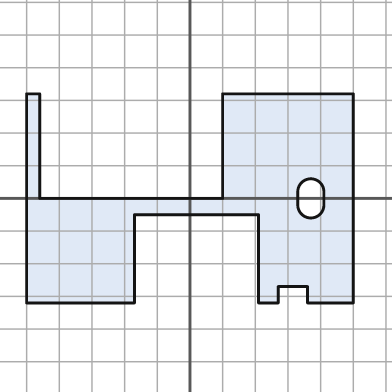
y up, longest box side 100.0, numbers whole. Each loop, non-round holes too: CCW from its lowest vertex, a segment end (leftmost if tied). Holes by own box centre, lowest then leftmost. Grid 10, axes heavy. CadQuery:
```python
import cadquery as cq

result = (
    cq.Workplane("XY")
    .moveTo(-50.0, -32.0)
    .lineTo(-17.0, -32.0)
    .lineTo(-17.0, -5.0)
    .lineTo(21.0, -5.0)
    .lineTo(21.0, -32.0)
    .lineTo(27.0, -32.0)
    .lineTo(27.0, -27.0)
    .lineTo(36.0, -27.0)
    .lineTo(36.0, -32.0)
    .lineTo(50.0, -32.0)
    .lineTo(50.0, 32.0)
    .lineTo(10.0, 32.0)
    .lineTo(10.0, 0.0)
    .lineTo(-46.0, 0.0)
    .lineTo(-46.0, 32.0)
    .lineTo(-50.0, 32.0)
    .close()
    .moveTo(33.0, -2.0)
    .threePointArc((37.0, -6.0), (41.0, -2.0))
    .lineTo(41.0, 2.0)
    .threePointArc((37.0, 6.0), (33.0, 2.0))
    .close()
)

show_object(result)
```